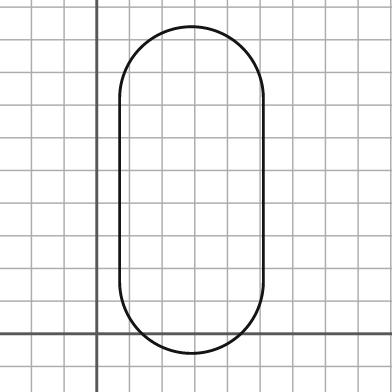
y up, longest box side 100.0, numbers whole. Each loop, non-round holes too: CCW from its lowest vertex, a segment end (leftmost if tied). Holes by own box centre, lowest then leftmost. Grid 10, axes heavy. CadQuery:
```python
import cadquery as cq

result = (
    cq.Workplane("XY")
    .moveTo(7.0, 16.0)
    .threePointArc((29.0, -6.0), (51.0, 16.0))
    .lineTo(51.0, 72.0)
    .threePointArc((29.0, 94.0), (7.0, 72.0))
    .close()
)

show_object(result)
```